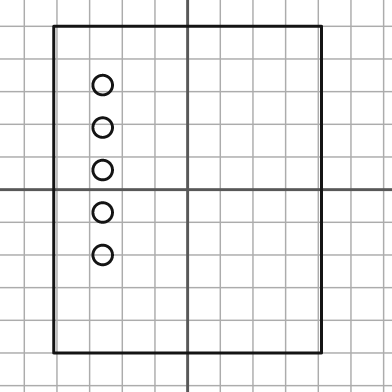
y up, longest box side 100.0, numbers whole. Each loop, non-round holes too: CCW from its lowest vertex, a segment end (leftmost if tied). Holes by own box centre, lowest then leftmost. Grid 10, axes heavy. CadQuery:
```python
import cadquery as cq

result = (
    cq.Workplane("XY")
    .moveTo(-41.0, -50.0)
    .lineTo(41.0, -50.0)
    .lineTo(41.0, 50.0)
    .lineTo(-41.0, 50.0)
    .close()
    .moveTo(-26.0, -20.0)
    .circle(3.0)
    .moveTo(-26.0, -7.0)
    .circle(3.0)
    .moveTo(-26.0, 6.0)
    .circle(3.0)
    .moveTo(-26.0, 19.0)
    .circle(3.0)
    .moveTo(-26.0, 32.0)
    .circle(3.0)
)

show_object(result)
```